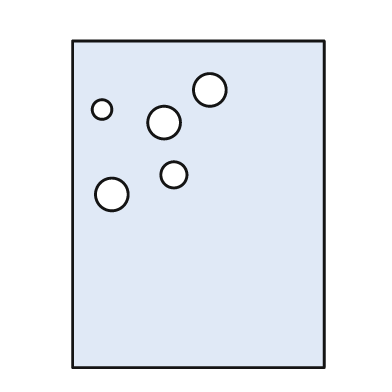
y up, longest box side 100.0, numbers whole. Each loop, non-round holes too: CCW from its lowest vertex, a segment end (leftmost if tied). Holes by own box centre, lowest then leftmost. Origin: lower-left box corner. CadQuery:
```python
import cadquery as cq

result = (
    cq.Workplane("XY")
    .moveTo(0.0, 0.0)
    .lineTo(77.0, 0.0)
    .lineTo(77.0, 100.0)
    .lineTo(0.0, 100.0)
    .close()
    .moveTo(12.0, 53.0)
    .circle(5.0)
    .moveTo(31.0, 59.0)
    .circle(4.0)
    .moveTo(28.0, 75.0)
    .circle(5.0)
    .moveTo(9.0, 79.0)
    .circle(3.0)
    .moveTo(42.0, 85.0)
    .circle(5.0)
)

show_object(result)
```